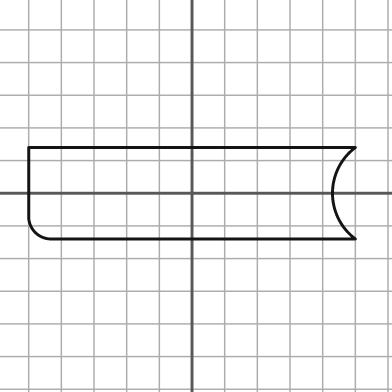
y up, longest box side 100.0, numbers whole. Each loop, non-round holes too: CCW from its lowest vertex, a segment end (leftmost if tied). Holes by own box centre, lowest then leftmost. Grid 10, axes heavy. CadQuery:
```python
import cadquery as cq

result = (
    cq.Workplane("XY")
    .moveTo(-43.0, -14.0)
    .lineTo(50.0, -14.0)
    .threePointArc((43.0, 0.0), (50.0, 14.0))
    .lineTo(-50.0, 14.0)
    .lineTo(-50.0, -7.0)
    .threePointArc((-48.0, -12.0), (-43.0, -14.0))
    .close()
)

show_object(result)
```